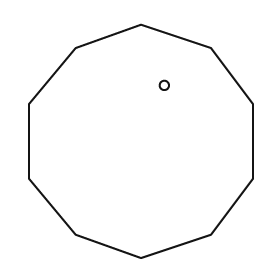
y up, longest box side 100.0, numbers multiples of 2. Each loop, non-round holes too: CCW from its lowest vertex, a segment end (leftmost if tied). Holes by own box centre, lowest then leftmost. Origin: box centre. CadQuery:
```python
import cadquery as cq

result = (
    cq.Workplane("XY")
    .moveTo(0.0, -50.0)
    .lineTo(30.0, -40.0)
    .lineTo(48.0, -16.0)
    .lineTo(48.0, 16.0)
    .lineTo(30.0, 40.0)
    .lineTo(0.0, 50.0)
    .lineTo(-28.0, 40.0)
    .lineTo(-48.0, 16.0)
    .lineTo(-48.0, -16.0)
    .lineTo(-28.0, -40.0)
    .close()
    .moveTo(10.0, 24.0)
    .circle(2.0)
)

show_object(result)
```